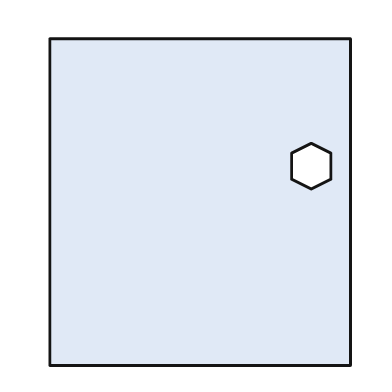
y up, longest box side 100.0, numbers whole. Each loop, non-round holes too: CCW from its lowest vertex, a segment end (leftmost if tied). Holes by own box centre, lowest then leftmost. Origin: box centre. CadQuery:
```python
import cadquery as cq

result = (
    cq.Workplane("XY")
    .moveTo(-46.0, -50.0)
    .lineTo(46.0, -50.0)
    .lineTo(46.0, 50.0)
    .lineTo(-46.0, 50.0)
    .close()
    .moveTo(34.0, 4.0)
    .lineTo(40.0, 7.0)
    .lineTo(40.0, 15.0)
    .lineTo(34.0, 18.0)
    .lineTo(28.0, 15.0)
    .lineTo(28.0, 7.0)
    .close()
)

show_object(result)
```